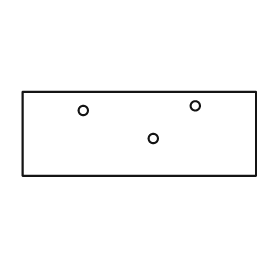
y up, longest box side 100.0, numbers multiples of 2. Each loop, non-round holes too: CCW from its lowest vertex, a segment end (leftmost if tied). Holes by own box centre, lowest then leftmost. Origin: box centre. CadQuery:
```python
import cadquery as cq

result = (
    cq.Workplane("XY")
    .moveTo(-50.0, -18.0)
    .lineTo(50.0, -18.0)
    .lineTo(50.0, 18.0)
    .lineTo(-50.0, 18.0)
    .close()
    .moveTo(6.0, -2.0)
    .circle(2.0)
    .moveTo(-24.0, 10.0)
    .circle(2.0)
    .moveTo(24.0, 12.0)
    .circle(2.0)
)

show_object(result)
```